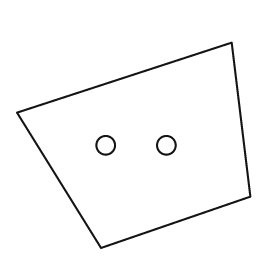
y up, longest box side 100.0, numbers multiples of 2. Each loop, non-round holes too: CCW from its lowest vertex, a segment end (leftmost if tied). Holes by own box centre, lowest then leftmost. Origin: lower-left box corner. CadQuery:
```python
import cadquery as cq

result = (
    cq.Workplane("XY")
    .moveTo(36.0, 0.0)
    .lineTo(100.0, 22.0)
    .lineTo(92.0, 88.0)
    .lineTo(0.0, 58.0)
    .close()
    .moveTo(38.0, 44.0)
    .circle(4.0)
    .moveTo(64.0, 44.0)
    .circle(4.0)
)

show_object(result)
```